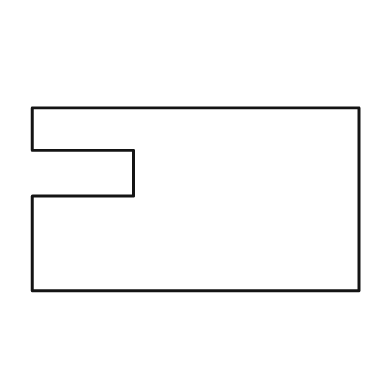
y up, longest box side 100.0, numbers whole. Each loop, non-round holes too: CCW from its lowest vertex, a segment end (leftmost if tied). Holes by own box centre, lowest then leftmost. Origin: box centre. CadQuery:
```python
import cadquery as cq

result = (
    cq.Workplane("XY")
    .moveTo(-50.0, -28.0)
    .lineTo(50.0, -28.0)
    .lineTo(50.0, 28.0)
    .lineTo(-50.0, 28.0)
    .lineTo(-50.0, 15.0)
    .lineTo(-19.0, 15.0)
    .lineTo(-19.0, 1.0)
    .lineTo(-50.0, 1.0)
    .close()
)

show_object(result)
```